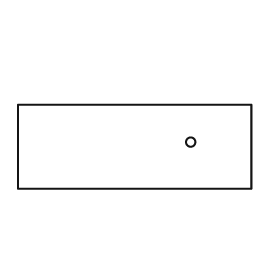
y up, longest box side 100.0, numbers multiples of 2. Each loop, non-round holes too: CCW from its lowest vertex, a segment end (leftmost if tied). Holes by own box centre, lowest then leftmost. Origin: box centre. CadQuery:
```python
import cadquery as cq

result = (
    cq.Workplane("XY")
    .moveTo(-50.0, -18.0)
    .lineTo(50.0, -18.0)
    .lineTo(50.0, 18.0)
    .lineTo(-50.0, 18.0)
    .close()
    .moveTo(24.0, 2.0)
    .circle(2.0)
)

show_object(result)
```